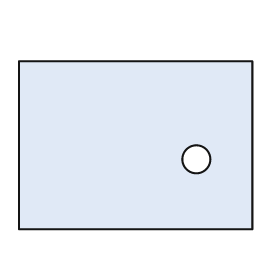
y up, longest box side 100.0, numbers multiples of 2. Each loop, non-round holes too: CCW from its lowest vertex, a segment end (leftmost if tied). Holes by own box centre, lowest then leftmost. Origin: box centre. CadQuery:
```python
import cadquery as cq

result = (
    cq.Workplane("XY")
    .moveTo(-50.0, -36.0)
    .lineTo(50.0, -36.0)
    .lineTo(50.0, 36.0)
    .lineTo(-50.0, 36.0)
    .close()
    .moveTo(26.0, -6.0)
    .circle(6.0)
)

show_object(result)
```